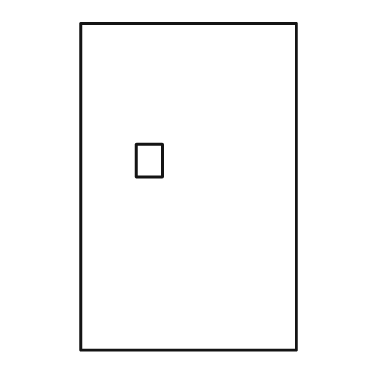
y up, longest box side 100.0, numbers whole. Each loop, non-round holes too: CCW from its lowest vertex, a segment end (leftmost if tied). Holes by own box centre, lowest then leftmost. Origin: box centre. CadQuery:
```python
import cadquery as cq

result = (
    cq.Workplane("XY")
    .moveTo(-33.0, -50.0)
    .lineTo(33.0, -50.0)
    .lineTo(33.0, 50.0)
    .lineTo(-33.0, 50.0)
    .close()
    .moveTo(-16.0, 3.0)
    .lineTo(-8.0, 3.0)
    .lineTo(-8.0, 13.0)
    .lineTo(-16.0, 13.0)
    .close()
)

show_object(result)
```